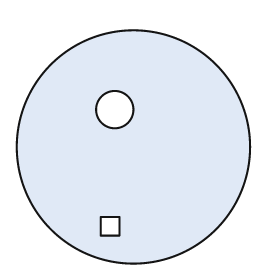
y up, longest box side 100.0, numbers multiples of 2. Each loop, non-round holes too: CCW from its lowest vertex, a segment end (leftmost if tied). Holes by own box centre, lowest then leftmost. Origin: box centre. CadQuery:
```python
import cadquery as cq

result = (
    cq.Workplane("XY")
    .moveTo(0.0, 0.0)
    .circle(50.0)
    .moveTo(-14.0, -38.0)
    .lineTo(-6.0, -38.0)
    .lineTo(-6.0, -30.0)
    .lineTo(-14.0, -30.0)
    .close()
    .moveTo(-8.0, 16.0)
    .circle(8.0)
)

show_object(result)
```